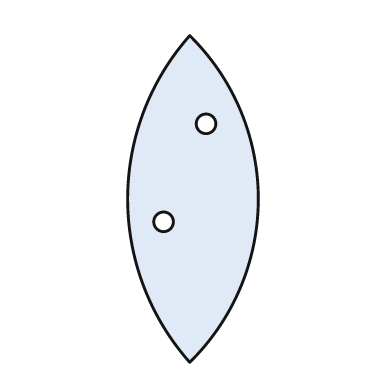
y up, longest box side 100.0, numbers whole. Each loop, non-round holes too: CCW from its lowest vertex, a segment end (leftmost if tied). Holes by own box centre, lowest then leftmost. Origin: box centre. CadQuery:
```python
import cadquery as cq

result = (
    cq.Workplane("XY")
    .moveTo(-1.0, -50.0)
    .threePointArc((20.0, 0.0), (-1.0, 50.0))
    .threePointArc((-20.0, 0.0), (-1.0, -50.0))
    .close()
    .moveTo(-9.0, -7.0)
    .circle(3.0)
    .moveTo(4.0, 23.0)
    .circle(3.0)
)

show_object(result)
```